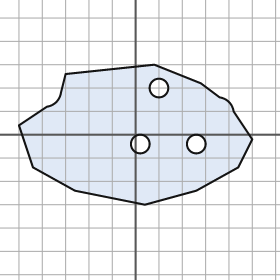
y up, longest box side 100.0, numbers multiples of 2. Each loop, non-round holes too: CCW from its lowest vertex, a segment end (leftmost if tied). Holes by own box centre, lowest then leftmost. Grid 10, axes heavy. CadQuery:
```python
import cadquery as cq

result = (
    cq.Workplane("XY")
    .moveTo(4.0, -30.0)
    .lineTo(26.0, -24.0)
    .lineTo(44.0, -14.0)
    .lineTo(50.0, -2.0)
    .lineTo(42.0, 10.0)
    .threePointArc((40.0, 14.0), (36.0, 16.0))
    .lineTo(28.0, 22.0)
    .lineTo(8.0, 30.0)
    .lineTo(-30.0, 26.0)
    .lineTo(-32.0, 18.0)
    .threePointArc((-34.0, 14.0), (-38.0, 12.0))
    .lineTo(-50.0, 4.0)
    .lineTo(-44.0, -14.0)
    .lineTo(-26.0, -24.0)
    .close()
    .moveTo(2.0, -4.0)
    .circle(4.0)
    .moveTo(26.0, -4.0)
    .circle(4.0)
    .moveTo(10.0, 20.0)
    .circle(4.0)
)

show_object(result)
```